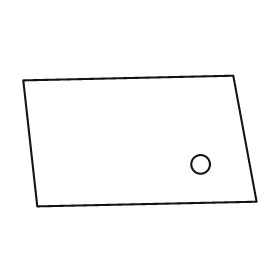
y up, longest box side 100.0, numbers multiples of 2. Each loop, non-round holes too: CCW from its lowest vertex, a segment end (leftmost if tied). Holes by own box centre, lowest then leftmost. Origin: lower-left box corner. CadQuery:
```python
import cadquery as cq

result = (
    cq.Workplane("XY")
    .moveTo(6.0, 0.0)
    .lineTo(100.0, 2.0)
    .lineTo(90.0, 56.0)
    .lineTo(0.0, 54.0)
    .close()
    .moveTo(76.0, 18.0)
    .circle(4.0)
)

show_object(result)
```